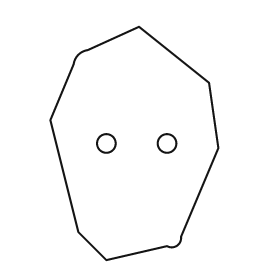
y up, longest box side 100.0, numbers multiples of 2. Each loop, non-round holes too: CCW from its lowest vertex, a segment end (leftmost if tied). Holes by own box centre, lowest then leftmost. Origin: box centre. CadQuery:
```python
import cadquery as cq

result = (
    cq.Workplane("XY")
    .moveTo(-12.0, -50.0)
    .lineTo(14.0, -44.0)
    .threePointArc((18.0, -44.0), (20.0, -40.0))
    .lineTo(36.0, -2.0)
    .lineTo(32.0, 26.0)
    .lineTo(2.0, 50.0)
    .lineTo(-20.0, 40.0)
    .threePointArc((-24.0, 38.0), (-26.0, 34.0))
    .lineTo(-36.0, 10.0)
    .lineTo(-24.0, -38.0)
    .close()
    .moveTo(-12.0, 0.0)
    .circle(4.0)
    .moveTo(14.0, 0.0)
    .circle(4.0)
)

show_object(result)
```